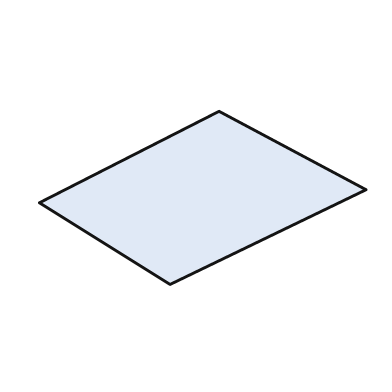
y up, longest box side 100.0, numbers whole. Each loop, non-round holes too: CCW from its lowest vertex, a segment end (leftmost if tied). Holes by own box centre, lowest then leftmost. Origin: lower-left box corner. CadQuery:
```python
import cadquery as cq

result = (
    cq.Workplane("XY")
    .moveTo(40.0, 0.0)
    .lineTo(100.0, 29.0)
    .lineTo(55.0, 53.0)
    .lineTo(0.0, 25.0)
    .close()
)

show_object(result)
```